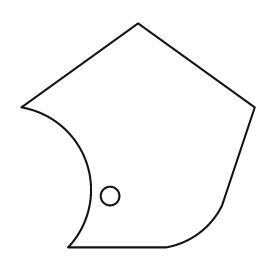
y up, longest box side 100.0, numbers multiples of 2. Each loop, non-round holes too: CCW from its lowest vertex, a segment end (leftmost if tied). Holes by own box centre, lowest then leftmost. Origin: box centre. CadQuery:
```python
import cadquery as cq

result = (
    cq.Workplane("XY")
    .moveTo(-30.0, -48.0)
    .lineTo(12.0, -48.0)
    .threePointArc((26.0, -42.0), (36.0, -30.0))
    .lineTo(50.0, 12.0)
    .lineTo(0.0, 48.0)
    .lineTo(-50.0, 12.0)
    .threePointArc((-22.0, -12.0), (-30.0, -48.0))
    .close()
    .moveTo(-12.0, -26.0)
    .circle(4.0)
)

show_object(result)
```